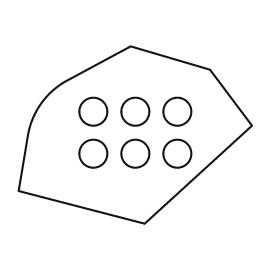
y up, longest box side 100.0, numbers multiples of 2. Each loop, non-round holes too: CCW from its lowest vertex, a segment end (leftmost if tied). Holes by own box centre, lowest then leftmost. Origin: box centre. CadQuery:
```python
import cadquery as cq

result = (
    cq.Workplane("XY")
    .moveTo(4.0, -38.0)
    .lineTo(50.0, 4.0)
    .lineTo(32.0, 28.0)
    .lineTo(-2.0, 38.0)
    .lineTo(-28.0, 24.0)
    .threePointArc((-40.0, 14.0), (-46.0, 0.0))
    .lineTo(-50.0, -24.0)
    .close()
    .moveTo(-18.0, -8.0)
    .circle(6.0)
    .moveTo(0.0, -8.0)
    .circle(6.0)
    .moveTo(18.0, -8.0)
    .circle(6.0)
    .moveTo(-18.0, 10.0)
    .circle(6.0)
    .moveTo(0.0, 10.0)
    .circle(6.0)
    .moveTo(18.0, 10.0)
    .circle(6.0)
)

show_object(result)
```